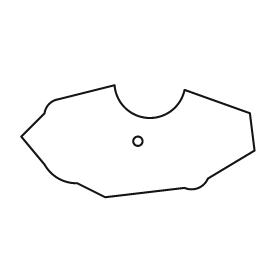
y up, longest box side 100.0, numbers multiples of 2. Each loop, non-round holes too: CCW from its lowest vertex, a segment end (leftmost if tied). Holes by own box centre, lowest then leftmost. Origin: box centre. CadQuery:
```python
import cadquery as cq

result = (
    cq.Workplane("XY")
    .moveTo(-14.0, -24.0)
    .lineTo(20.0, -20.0)
    .threePointArc((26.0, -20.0), (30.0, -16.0))
    .lineTo(50.0, -4.0)
    .lineTo(48.0, 12.0)
    .lineTo(20.0, 22.0)
    .threePointArc((4.0, 10.0), (-10.0, 24.0))
    .lineTo(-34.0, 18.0)
    .threePointArc((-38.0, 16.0), (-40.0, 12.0))
    .lineTo(-50.0, 2.0)
    .lineTo(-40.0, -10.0)
    .threePointArc((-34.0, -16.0), (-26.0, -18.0))
    .close()
    .moveTo(0.0, 0.0)
    .circle(2.0)
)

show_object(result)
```